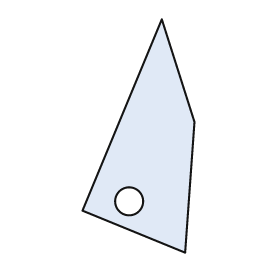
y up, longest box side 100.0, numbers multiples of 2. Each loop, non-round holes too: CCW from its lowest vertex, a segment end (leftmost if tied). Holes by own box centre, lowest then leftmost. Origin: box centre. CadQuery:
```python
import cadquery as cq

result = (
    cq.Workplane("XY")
    .moveTo(20.0, -50.0)
    .lineTo(24.0, 6.0)
    .lineTo(10.0, 50.0)
    .lineTo(-24.0, -32.0)
    .close()
    .moveTo(-4.0, -28.0)
    .circle(6.0)
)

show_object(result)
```